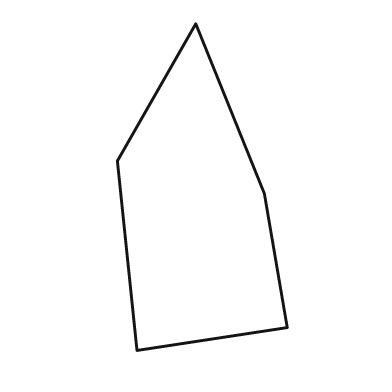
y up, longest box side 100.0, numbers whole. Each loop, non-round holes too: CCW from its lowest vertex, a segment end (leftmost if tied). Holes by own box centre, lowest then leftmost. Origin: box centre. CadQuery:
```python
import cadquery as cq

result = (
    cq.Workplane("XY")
    .moveTo(-20.0, -50.0)
    .lineTo(26.0, -43.0)
    .lineTo(19.0, -2.0)
    .lineTo(-2.0, 50.0)
    .lineTo(-26.0, 8.0)
    .close()
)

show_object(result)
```